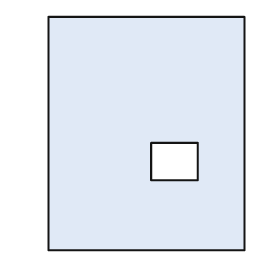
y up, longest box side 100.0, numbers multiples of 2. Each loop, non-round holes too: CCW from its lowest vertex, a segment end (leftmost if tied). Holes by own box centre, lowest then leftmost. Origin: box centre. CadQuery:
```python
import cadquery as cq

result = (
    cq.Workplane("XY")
    .moveTo(-42.0, -50.0)
    .lineTo(42.0, -50.0)
    .lineTo(42.0, 50.0)
    .lineTo(-42.0, 50.0)
    .close()
    .moveTo(2.0, -20.0)
    .lineTo(22.0, -20.0)
    .lineTo(22.0, -4.0)
    .lineTo(2.0, -4.0)
    .close()
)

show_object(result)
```